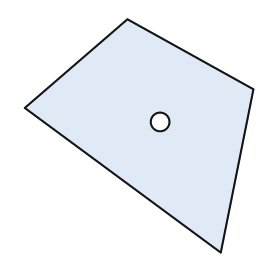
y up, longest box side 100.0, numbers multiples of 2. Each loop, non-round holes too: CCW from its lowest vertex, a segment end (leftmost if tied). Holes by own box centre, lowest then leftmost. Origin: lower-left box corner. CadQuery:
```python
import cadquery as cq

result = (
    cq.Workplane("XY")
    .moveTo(84.0, 0.0)
    .lineTo(98.0, 70.0)
    .lineTo(44.0, 100.0)
    .lineTo(0.0, 62.0)
    .close()
    .moveTo(58.0, 56.0)
    .circle(4.0)
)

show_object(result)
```